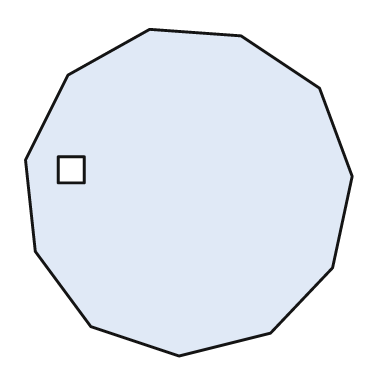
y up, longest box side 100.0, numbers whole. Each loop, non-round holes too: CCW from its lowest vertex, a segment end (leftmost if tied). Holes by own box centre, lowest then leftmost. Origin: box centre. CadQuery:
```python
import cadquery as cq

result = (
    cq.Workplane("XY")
    .moveTo(-3.0, -50.0)
    .lineTo(25.0, -43.0)
    .lineTo(44.0, -23.0)
    .lineTo(50.0, 5.0)
    .lineTo(40.0, 32.0)
    .lineTo(16.0, 48.0)
    .lineTo(-12.0, 50.0)
    .lineTo(-37.0, 36.0)
    .lineTo(-50.0, 10.0)
    .lineTo(-47.0, -18.0)
    .lineTo(-30.0, -41.0)
    .close()
    .moveTo(-40.0, 3.0)
    .lineTo(-32.0, 3.0)
    .lineTo(-32.0, 11.0)
    .lineTo(-40.0, 11.0)
    .close()
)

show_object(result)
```